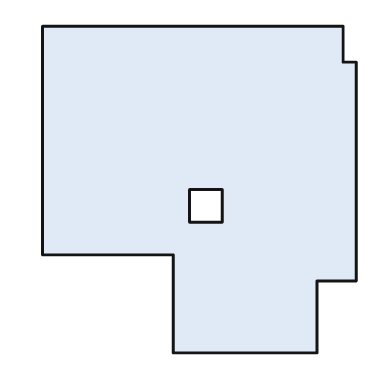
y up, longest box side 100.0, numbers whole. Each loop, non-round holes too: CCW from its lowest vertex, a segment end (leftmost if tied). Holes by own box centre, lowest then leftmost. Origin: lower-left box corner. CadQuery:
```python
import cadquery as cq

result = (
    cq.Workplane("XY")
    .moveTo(40.0, 0.0)
    .lineTo(84.0, 0.0)
    .lineTo(84.0, 22.0)
    .lineTo(96.0, 22.0)
    .lineTo(96.0, 89.0)
    .lineTo(92.0, 89.0)
    .lineTo(92.0, 100.0)
    .lineTo(0.0, 100.0)
    .lineTo(0.0, 30.0)
    .lineTo(40.0, 30.0)
    .close()
    .moveTo(45.0, 40.0)
    .lineTo(55.0, 40.0)
    .lineTo(55.0, 50.0)
    .lineTo(45.0, 50.0)
    .close()
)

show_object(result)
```